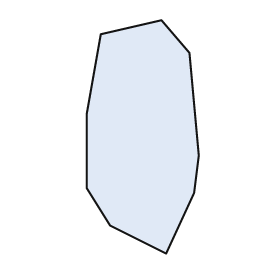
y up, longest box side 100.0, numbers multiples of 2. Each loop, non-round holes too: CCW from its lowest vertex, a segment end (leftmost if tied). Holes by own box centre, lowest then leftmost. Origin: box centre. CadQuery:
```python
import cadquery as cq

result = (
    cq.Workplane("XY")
    .moveTo(10.0, -50.0)
    .lineTo(22.0, -24.0)
    .lineTo(24.0, -8.0)
    .lineTo(20.0, 36.0)
    .lineTo(8.0, 50.0)
    .lineTo(-18.0, 44.0)
    .lineTo(-24.0, 10.0)
    .lineTo(-24.0, -22.0)
    .lineTo(-14.0, -38.0)
    .close()
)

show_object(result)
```